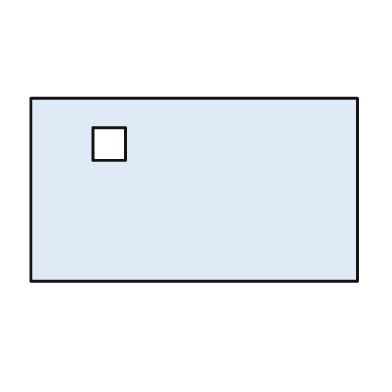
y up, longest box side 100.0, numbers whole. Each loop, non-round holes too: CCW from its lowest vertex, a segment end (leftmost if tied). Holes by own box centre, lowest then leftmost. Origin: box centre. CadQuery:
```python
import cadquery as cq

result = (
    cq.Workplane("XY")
    .moveTo(-50.0, -28.0)
    .lineTo(50.0, -28.0)
    .lineTo(50.0, 28.0)
    .lineTo(-50.0, 28.0)
    .close()
    .moveTo(-31.0, 9.0)
    .lineTo(-21.0, 9.0)
    .lineTo(-21.0, 19.0)
    .lineTo(-31.0, 19.0)
    .close()
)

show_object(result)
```